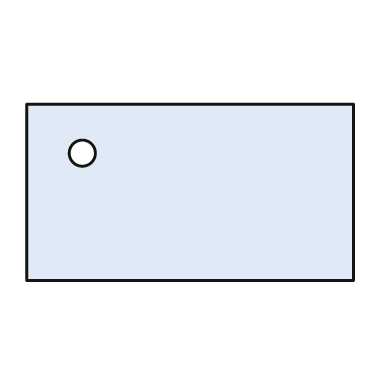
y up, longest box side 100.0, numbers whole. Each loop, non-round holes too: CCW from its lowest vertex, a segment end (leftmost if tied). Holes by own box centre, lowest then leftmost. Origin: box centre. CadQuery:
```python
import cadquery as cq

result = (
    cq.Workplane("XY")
    .moveTo(-50.0, -27.0)
    .lineTo(50.0, -27.0)
    .lineTo(50.0, 27.0)
    .lineTo(-50.0, 27.0)
    .close()
    .moveTo(-33.0, 12.0)
    .circle(4.0)
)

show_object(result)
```